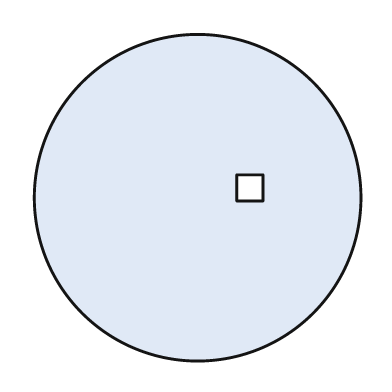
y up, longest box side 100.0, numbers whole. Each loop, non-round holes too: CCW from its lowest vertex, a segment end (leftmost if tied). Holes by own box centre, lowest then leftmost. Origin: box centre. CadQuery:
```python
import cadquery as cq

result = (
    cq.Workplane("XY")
    .moveTo(0.0, 0.0)
    .circle(50.0)
    .moveTo(12.0, -1.0)
    .lineTo(20.0, -1.0)
    .lineTo(20.0, 7.0)
    .lineTo(12.0, 7.0)
    .close()
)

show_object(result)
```